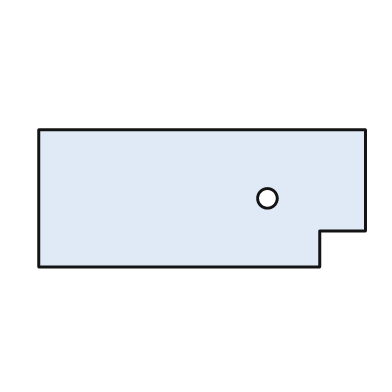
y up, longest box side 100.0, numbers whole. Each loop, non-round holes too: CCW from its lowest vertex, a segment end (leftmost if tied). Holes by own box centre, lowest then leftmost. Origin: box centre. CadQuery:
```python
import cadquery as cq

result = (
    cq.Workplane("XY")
    .moveTo(-50.0, -21.0)
    .lineTo(36.0, -21.0)
    .lineTo(36.0, -10.0)
    .lineTo(50.0, -10.0)
    .lineTo(50.0, 21.0)
    .lineTo(-50.0, 21.0)
    .close()
    .moveTo(20.0, 0.0)
    .circle(3.0)
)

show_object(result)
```